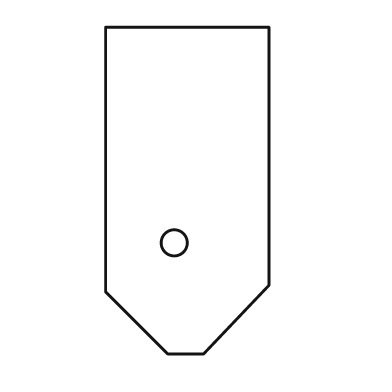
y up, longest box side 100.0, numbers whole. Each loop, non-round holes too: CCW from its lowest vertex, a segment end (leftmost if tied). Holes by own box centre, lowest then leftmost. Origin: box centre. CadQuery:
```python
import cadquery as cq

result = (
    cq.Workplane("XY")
    .moveTo(-6.0, -50.0)
    .lineTo(5.0, -50.0)
    .lineTo(25.0, -29.0)
    .lineTo(25.0, 50.0)
    .lineTo(-25.0, 50.0)
    .lineTo(-25.0, -31.0)
    .close()
    .moveTo(-4.0, -16.0)
    .circle(4.0)
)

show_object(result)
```